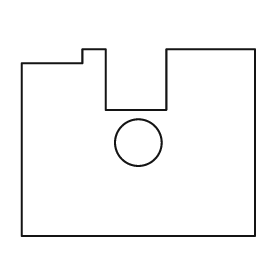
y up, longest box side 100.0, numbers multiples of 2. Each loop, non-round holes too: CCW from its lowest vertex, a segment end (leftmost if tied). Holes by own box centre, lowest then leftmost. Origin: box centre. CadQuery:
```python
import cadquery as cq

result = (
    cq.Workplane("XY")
    .moveTo(-50.0, -40.0)
    .lineTo(50.0, -40.0)
    .lineTo(50.0, 40.0)
    .lineTo(12.0, 40.0)
    .lineTo(12.0, 14.0)
    .lineTo(-14.0, 14.0)
    .lineTo(-14.0, 40.0)
    .lineTo(-24.0, 40.0)
    .lineTo(-24.0, 34.0)
    .lineTo(-50.0, 34.0)
    .close()
    .moveTo(0.0, 0.0)
    .circle(10.0)
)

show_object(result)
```